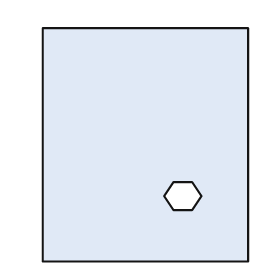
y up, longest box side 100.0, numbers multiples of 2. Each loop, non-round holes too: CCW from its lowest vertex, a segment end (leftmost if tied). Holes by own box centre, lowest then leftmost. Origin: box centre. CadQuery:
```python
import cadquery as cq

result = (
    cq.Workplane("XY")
    .moveTo(-44.0, -50.0)
    .lineTo(44.0, -50.0)
    .lineTo(44.0, 50.0)
    .lineTo(-44.0, 50.0)
    .close()
    .moveTo(12.0, -28.0)
    .lineTo(20.0, -28.0)
    .lineTo(24.0, -22.0)
    .lineTo(20.0, -16.0)
    .lineTo(12.0, -16.0)
    .lineTo(8.0, -22.0)
    .close()
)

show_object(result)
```